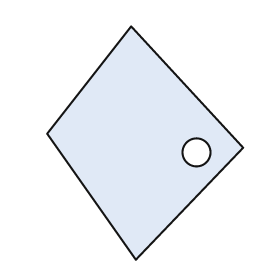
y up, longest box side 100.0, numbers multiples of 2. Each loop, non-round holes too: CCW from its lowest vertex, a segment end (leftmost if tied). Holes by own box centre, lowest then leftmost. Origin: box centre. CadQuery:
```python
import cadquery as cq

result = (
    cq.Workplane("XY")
    .moveTo(-4.0, -50.0)
    .lineTo(42.0, -2.0)
    .lineTo(-6.0, 50.0)
    .lineTo(-42.0, 4.0)
    .close()
    .moveTo(22.0, -4.0)
    .circle(6.0)
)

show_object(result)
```